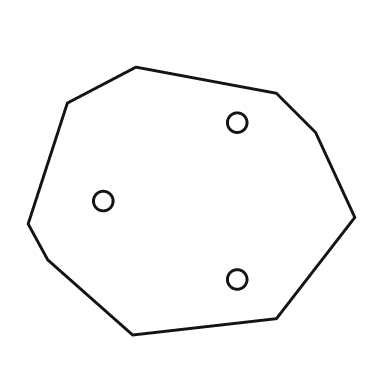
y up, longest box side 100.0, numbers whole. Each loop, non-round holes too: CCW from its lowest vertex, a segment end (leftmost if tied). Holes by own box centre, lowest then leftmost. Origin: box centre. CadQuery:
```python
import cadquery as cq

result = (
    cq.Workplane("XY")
    .moveTo(-18.0, -41.0)
    .lineTo(26.0, -36.0)
    .lineTo(50.0, -5.0)
    .lineTo(38.0, 21.0)
    .lineTo(26.0, 33.0)
    .lineTo(-17.0, 41.0)
    .lineTo(-38.0, 30.0)
    .lineTo(-50.0, -7.0)
    .lineTo(-44.0, -18.0)
    .close()
    .moveTo(14.0, -24.0)
    .circle(3.0)
    .moveTo(-27.0, 0.0)
    .circle(3.0)
    .moveTo(14.0, 24.0)
    .circle(3.0)
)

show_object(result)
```